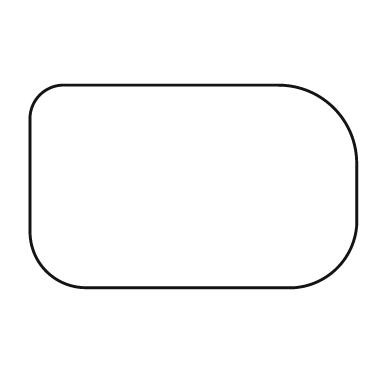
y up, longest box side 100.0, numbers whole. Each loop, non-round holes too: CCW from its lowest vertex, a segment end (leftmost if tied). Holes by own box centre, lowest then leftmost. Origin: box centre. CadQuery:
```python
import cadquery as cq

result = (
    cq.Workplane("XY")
    .moveTo(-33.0, -31.0)
    .lineTo(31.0, -31.0)
    .threePointArc((44.0, -25.0), (50.0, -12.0))
    .lineTo(50.0, 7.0)
    .threePointArc((43.0, 24.0), (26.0, 31.0))
    .lineTo(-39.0, 31.0)
    .threePointArc((-47.0, 28.0), (-50.0, 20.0))
    .lineTo(-50.0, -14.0)
    .threePointArc((-45.0, -26.0), (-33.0, -31.0))
    .close()
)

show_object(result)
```